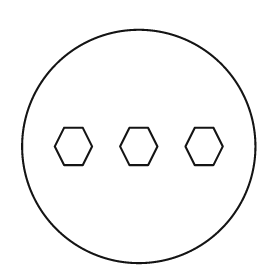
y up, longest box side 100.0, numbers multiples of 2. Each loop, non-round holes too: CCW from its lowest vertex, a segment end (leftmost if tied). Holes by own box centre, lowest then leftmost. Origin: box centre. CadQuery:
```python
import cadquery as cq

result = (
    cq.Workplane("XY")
    .moveTo(0.0, 0.0)
    .circle(50.0)
    .moveTo(-32.0, -8.0)
    .lineTo(-24.0, -8.0)
    .lineTo(-20.0, 0.0)
    .lineTo(-24.0, 8.0)
    .lineTo(-32.0, 8.0)
    .lineTo(-36.0, 0.0)
    .close()
    .moveTo(-4.0, -8.0)
    .lineTo(4.0, -8.0)
    .lineTo(8.0, 0.0)
    .lineTo(4.0, 8.0)
    .lineTo(-4.0, 8.0)
    .lineTo(-8.0, 0.0)
    .close()
    .moveTo(24.0, -8.0)
    .lineTo(32.0, -8.0)
    .lineTo(36.0, 0.0)
    .lineTo(32.0, 8.0)
    .lineTo(24.0, 8.0)
    .lineTo(20.0, 0.0)
    .close()
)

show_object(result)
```